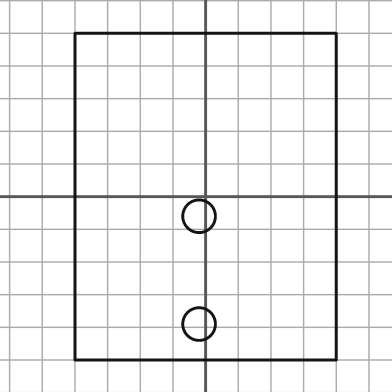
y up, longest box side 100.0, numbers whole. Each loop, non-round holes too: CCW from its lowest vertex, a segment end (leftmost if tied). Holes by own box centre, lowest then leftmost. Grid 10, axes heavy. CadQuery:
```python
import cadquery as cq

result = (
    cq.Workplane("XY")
    .moveTo(-40.0, -50.0)
    .lineTo(40.0, -50.0)
    .lineTo(40.0, 50.0)
    .lineTo(-40.0, 50.0)
    .close()
    .moveTo(-2.0, -39.0)
    .circle(5.0)
    .moveTo(-2.0, -6.0)
    .circle(5.0)
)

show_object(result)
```